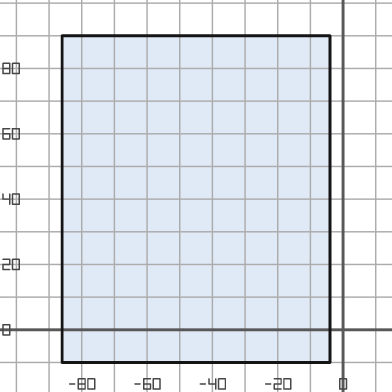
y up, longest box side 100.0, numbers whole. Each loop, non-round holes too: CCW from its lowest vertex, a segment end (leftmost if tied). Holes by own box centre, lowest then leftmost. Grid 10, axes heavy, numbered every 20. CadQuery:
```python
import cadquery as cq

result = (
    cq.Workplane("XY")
    .moveTo(-86.0, -10.0)
    .lineTo(-4.0, -10.0)
    .lineTo(-4.0, 90.0)
    .lineTo(-86.0, 90.0)
    .close()
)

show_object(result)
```